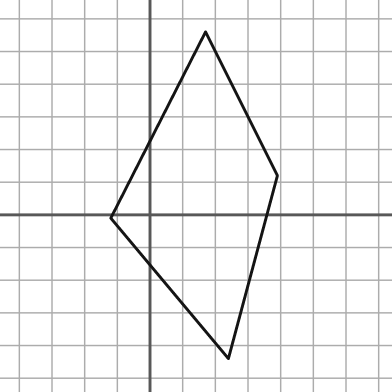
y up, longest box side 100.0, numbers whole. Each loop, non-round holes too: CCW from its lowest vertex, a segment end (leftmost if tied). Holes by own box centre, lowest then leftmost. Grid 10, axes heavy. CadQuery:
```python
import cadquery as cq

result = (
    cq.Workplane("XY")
    .moveTo(24.0, -44.0)
    .lineTo(39.0, 12.0)
    .lineTo(17.0, 56.0)
    .lineTo(-12.0, -1.0)
    .close()
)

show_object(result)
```